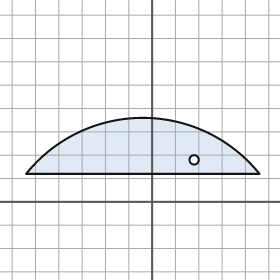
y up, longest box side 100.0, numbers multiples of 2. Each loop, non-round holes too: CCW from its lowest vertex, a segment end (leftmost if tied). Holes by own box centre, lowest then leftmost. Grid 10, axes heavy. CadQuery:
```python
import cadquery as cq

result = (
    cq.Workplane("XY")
    .moveTo(-54.0, 12.0)
    .lineTo(46.0, 12.0)
    .threePointArc((-4.0, 36.0), (-54.0, 12.0))
    .close()
    .moveTo(18.0, 18.0)
    .circle(2.0)
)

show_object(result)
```